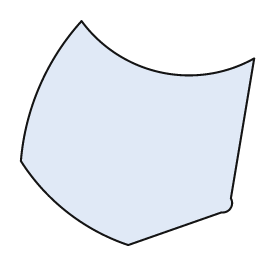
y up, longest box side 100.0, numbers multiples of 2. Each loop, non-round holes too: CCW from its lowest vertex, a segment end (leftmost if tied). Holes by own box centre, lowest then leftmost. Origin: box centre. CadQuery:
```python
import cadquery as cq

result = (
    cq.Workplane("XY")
    .moveTo(-4.0, -48.0)
    .lineTo(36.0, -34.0)
    .threePointArc((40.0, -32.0), (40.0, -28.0))
    .lineTo(50.0, 32.0)
    .threePointArc((10.0, 26.0), (-24.0, 48.0))
    .threePointArc((-42.0, 20.0), (-50.0, -12.0))
    .threePointArc((-30.0, -34.0), (-4.0, -48.0))
    .close()
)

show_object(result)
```